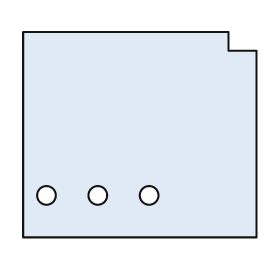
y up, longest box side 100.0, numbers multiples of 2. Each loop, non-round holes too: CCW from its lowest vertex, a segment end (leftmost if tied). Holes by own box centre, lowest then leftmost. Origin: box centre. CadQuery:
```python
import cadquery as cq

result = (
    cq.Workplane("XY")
    .moveTo(-50.0, -44.0)
    .lineTo(50.0, -44.0)
    .lineTo(50.0, 36.0)
    .lineTo(38.0, 36.0)
    .lineTo(38.0, 44.0)
    .lineTo(-50.0, 44.0)
    .close()
    .moveTo(-40.0, -26.0)
    .circle(4.0)
    .moveTo(-18.0, -26.0)
    .circle(4.0)
    .moveTo(4.0, -26.0)
    .circle(4.0)
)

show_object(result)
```